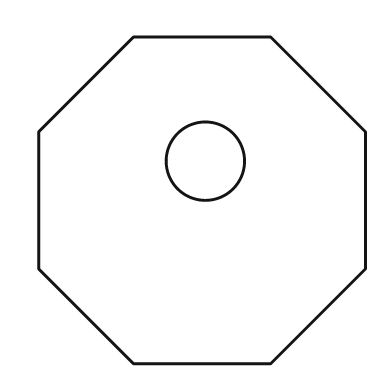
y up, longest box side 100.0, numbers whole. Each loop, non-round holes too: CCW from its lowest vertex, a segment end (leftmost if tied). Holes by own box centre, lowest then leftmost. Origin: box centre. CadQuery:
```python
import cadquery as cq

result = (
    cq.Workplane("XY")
    .moveTo(-21.0, -50.0)
    .lineTo(21.0, -50.0)
    .lineTo(50.0, -21.0)
    .lineTo(50.0, 21.0)
    .lineTo(21.0, 50.0)
    .lineTo(-21.0, 50.0)
    .lineTo(-50.0, 21.0)
    .lineTo(-50.0, -21.0)
    .close()
    .moveTo(1.0, 12.0)
    .circle(12.0)
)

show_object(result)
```